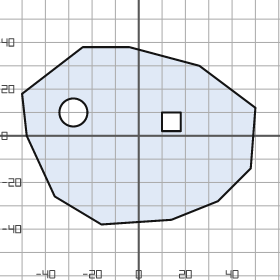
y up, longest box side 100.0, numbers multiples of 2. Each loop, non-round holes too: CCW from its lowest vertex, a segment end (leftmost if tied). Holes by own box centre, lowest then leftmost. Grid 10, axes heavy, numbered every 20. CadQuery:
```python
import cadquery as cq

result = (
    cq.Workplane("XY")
    .moveTo(-16.0, -38.0)
    .lineTo(14.0, -36.0)
    .lineTo(34.0, -28.0)
    .lineTo(48.0, -14.0)
    .lineTo(50.0, 12.0)
    .lineTo(26.0, 30.0)
    .lineTo(-4.0, 38.0)
    .lineTo(-24.0, 38.0)
    .lineTo(-50.0, 18.0)
    .lineTo(-48.0, 0.0)
    .lineTo(-36.0, -26.0)
    .close()
    .moveTo(10.0, 2.0)
    .lineTo(18.0, 2.0)
    .lineTo(18.0, 10.0)
    .lineTo(10.0, 10.0)
    .close()
    .moveTo(-28.0, 10.0)
    .circle(6.0)
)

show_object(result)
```